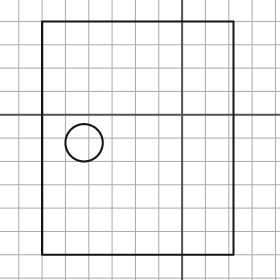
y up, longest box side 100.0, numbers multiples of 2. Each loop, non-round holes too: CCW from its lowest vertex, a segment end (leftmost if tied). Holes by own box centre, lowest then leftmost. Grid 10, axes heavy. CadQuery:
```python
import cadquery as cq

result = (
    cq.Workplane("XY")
    .moveTo(-60.0, -60.0)
    .lineTo(22.0, -60.0)
    .lineTo(22.0, 40.0)
    .lineTo(-60.0, 40.0)
    .close()
    .moveTo(-42.0, -12.0)
    .circle(8.0)
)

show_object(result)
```